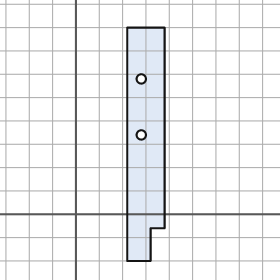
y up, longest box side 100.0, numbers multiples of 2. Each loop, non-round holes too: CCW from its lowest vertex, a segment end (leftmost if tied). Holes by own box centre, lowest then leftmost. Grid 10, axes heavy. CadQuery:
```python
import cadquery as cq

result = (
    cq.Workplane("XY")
    .moveTo(22.0, -20.0)
    .lineTo(32.0, -20.0)
    .lineTo(32.0, -6.0)
    .lineTo(38.0, -6.0)
    .lineTo(38.0, 80.0)
    .lineTo(22.0, 80.0)
    .close()
    .moveTo(28.0, 34.0)
    .circle(2.0)
    .moveTo(28.0, 58.0)
    .circle(2.0)
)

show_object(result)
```